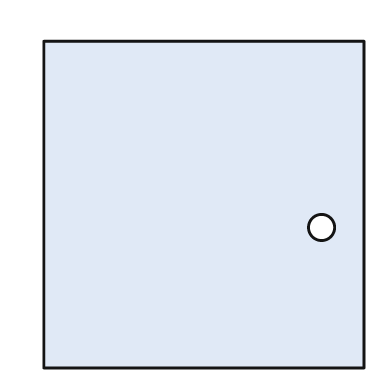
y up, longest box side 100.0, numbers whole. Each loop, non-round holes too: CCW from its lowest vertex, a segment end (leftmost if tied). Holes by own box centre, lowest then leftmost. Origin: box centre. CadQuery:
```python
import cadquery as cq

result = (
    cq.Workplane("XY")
    .moveTo(-49.0, -50.0)
    .lineTo(49.0, -50.0)
    .lineTo(49.0, 50.0)
    .lineTo(-49.0, 50.0)
    .close()
    .moveTo(36.0, -7.0)
    .circle(4.0)
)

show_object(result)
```